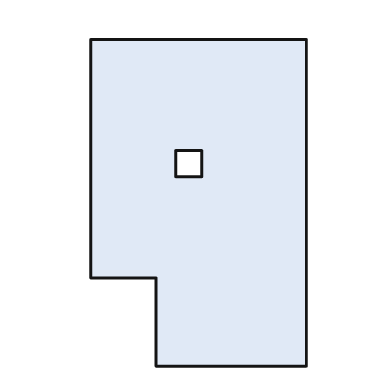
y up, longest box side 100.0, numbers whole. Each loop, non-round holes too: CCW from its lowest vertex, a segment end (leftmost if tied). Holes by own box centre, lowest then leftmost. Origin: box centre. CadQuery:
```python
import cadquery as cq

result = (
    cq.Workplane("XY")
    .moveTo(-13.0, -50.0)
    .lineTo(33.0, -50.0)
    .lineTo(33.0, 50.0)
    .lineTo(-33.0, 50.0)
    .lineTo(-33.0, -23.0)
    .lineTo(-13.0, -23.0)
    .close()
    .moveTo(-7.0, 8.0)
    .lineTo(1.0, 8.0)
    .lineTo(1.0, 16.0)
    .lineTo(-7.0, 16.0)
    .close()
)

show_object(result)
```